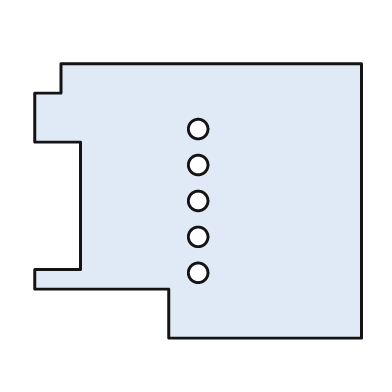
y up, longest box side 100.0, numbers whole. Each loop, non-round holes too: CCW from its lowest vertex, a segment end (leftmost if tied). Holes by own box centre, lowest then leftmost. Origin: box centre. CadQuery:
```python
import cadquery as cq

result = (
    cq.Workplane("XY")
    .moveTo(-9.0, -42.0)
    .lineTo(50.0, -42.0)
    .lineTo(50.0, 42.0)
    .lineTo(-42.0, 42.0)
    .lineTo(-42.0, 33.0)
    .lineTo(-50.0, 33.0)
    .lineTo(-50.0, 18.0)
    .lineTo(-36.0, 18.0)
    .lineTo(-36.0, -21.0)
    .lineTo(-50.0, -21.0)
    .lineTo(-50.0, -27.0)
    .lineTo(-9.0, -27.0)
    .close()
    .moveTo(0.0, -22.0)
    .circle(3.0)
    .moveTo(0.0, -11.0)
    .circle(3.0)
    .moveTo(0.0, 0.0)
    .circle(3.0)
    .moveTo(0.0, 11.0)
    .circle(3.0)
    .moveTo(0.0, 22.0)
    .circle(3.0)
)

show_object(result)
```